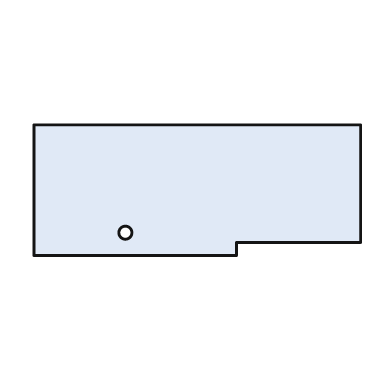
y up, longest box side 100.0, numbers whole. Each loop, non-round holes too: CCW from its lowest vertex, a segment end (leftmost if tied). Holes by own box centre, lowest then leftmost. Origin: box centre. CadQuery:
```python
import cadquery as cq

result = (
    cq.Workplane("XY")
    .moveTo(-50.0, -20.0)
    .lineTo(12.0, -20.0)
    .lineTo(12.0, -16.0)
    .lineTo(50.0, -16.0)
    .lineTo(50.0, 20.0)
    .lineTo(-50.0, 20.0)
    .close()
    .moveTo(-22.0, -13.0)
    .circle(2.0)
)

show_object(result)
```